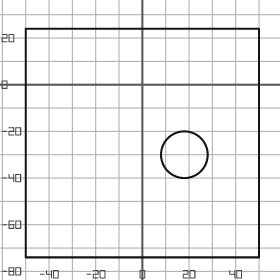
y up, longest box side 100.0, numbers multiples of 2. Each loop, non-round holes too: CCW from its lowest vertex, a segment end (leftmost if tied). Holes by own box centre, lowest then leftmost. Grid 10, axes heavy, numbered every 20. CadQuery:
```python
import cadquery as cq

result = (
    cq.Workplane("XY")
    .moveTo(-50.0, -74.0)
    .lineTo(50.0, -74.0)
    .lineTo(50.0, 24.0)
    .lineTo(-50.0, 24.0)
    .close()
    .moveTo(18.0, -30.0)
    .circle(10.0)
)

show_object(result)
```